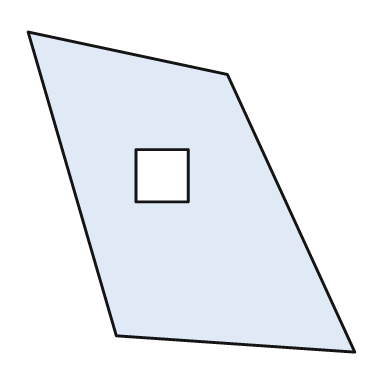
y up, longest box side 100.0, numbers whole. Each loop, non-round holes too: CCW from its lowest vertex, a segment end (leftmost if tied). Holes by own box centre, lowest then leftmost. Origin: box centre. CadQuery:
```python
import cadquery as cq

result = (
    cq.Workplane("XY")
    .moveTo(50.0, -49.0)
    .lineTo(11.0, 36.0)
    .lineTo(-50.0, 49.0)
    .lineTo(-23.0, -44.0)
    .close()
    .moveTo(-17.0, -3.0)
    .lineTo(-1.0, -3.0)
    .lineTo(-1.0, 13.0)
    .lineTo(-17.0, 13.0)
    .close()
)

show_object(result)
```